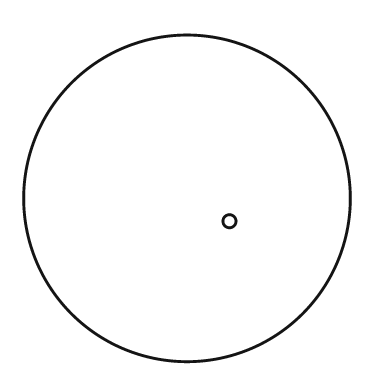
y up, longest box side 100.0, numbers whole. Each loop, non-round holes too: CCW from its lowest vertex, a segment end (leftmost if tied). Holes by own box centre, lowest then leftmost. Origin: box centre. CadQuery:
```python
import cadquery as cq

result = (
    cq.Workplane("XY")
    .moveTo(0.0, 0.0)
    .circle(50.0)
    .moveTo(13.0, -7.0)
    .circle(2.0)
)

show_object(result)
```